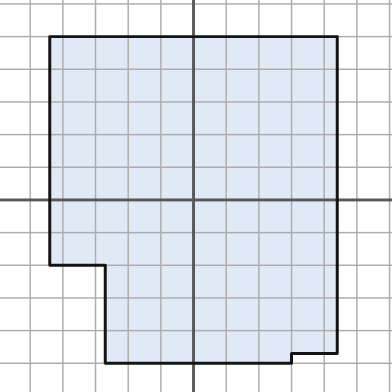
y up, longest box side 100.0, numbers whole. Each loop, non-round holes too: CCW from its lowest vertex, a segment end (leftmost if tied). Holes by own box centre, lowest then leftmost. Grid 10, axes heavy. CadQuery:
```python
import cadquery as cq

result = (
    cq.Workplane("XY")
    .moveTo(-27.0, -50.0)
    .lineTo(30.0, -50.0)
    .lineTo(30.0, -47.0)
    .lineTo(44.0, -47.0)
    .lineTo(44.0, 50.0)
    .lineTo(-44.0, 50.0)
    .lineTo(-44.0, -20.0)
    .lineTo(-27.0, -20.0)
    .close()
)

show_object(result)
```